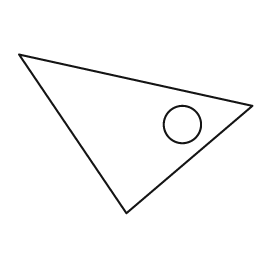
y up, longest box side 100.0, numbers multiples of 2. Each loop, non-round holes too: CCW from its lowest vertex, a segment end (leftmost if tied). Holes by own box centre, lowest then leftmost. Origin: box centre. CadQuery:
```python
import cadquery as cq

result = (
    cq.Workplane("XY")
    .moveTo(-4.0, -34.0)
    .lineTo(50.0, 12.0)
    .lineTo(-50.0, 34.0)
    .close()
    .moveTo(20.0, 4.0)
    .circle(8.0)
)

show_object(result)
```